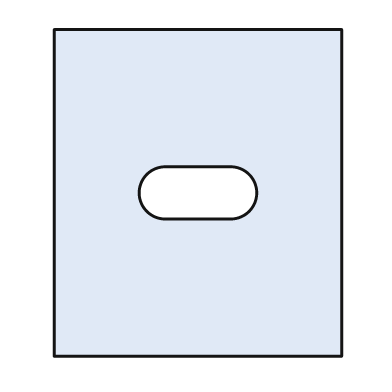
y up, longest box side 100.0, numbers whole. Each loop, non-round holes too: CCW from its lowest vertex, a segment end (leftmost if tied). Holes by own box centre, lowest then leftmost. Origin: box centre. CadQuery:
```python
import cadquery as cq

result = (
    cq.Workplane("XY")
    .moveTo(-44.0, -50.0)
    .lineTo(44.0, -50.0)
    .lineTo(44.0, 50.0)
    .lineTo(-44.0, 50.0)
    .close()
    .moveTo(-10.0, -8.0)
    .lineTo(10.0, -8.0)
    .threePointArc((18.0, 0.0), (10.0, 8.0))
    .lineTo(-10.0, 8.0)
    .threePointArc((-18.0, 0.0), (-10.0, -8.0))
    .close()
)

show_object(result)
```